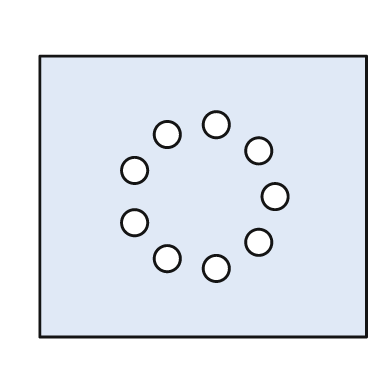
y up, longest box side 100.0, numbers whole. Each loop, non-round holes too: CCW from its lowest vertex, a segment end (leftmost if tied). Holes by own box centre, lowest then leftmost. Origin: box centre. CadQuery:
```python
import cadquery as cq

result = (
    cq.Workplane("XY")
    .moveTo(-50.0, -43.0)
    .lineTo(50.0, -43.0)
    .lineTo(50.0, 43.0)
    .lineTo(-50.0, 43.0)
    .close()
    .moveTo(4.0, -22.0)
    .circle(4.0)
    .moveTo(-11.0, -19.0)
    .circle(4.0)
    .moveTo(17.0, -14.0)
    .circle(4.0)
    .moveTo(-21.0, -8.0)
    .circle(4.0)
    .moveTo(22.0, 0.0)
    .circle(4.0)
    .moveTo(-21.0, 8.0)
    .circle(4.0)
    .moveTo(17.0, 14.0)
    .circle(4.0)
    .moveTo(-11.0, 19.0)
    .circle(4.0)
    .moveTo(4.0, 22.0)
    .circle(4.0)
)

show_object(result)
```